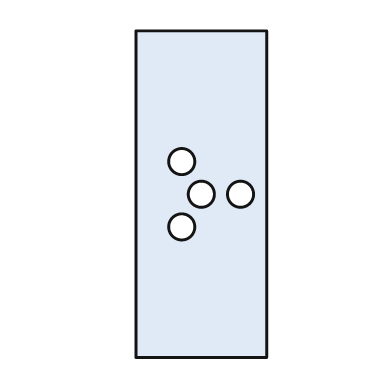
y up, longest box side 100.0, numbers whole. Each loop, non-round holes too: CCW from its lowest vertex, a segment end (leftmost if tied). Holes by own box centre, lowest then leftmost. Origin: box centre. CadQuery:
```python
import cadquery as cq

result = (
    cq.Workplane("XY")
    .moveTo(-20.0, -50.0)
    .lineTo(20.0, -50.0)
    .lineTo(20.0, 50.0)
    .lineTo(-20.0, 50.0)
    .close()
    .moveTo(-6.0, -10.0)
    .circle(4.0)
    .moveTo(0.0, 0.0)
    .circle(4.0)
    .moveTo(12.0, 0.0)
    .circle(4.0)
    .moveTo(-6.0, 10.0)
    .circle(4.0)
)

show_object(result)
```